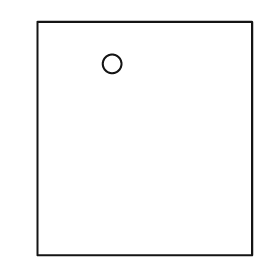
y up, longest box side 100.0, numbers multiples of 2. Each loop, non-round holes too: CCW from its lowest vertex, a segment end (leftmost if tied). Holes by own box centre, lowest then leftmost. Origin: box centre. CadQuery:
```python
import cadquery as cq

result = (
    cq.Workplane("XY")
    .moveTo(-46.0, -50.0)
    .lineTo(46.0, -50.0)
    .lineTo(46.0, 50.0)
    .lineTo(-46.0, 50.0)
    .close()
    .moveTo(-14.0, 32.0)
    .circle(4.0)
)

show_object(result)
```